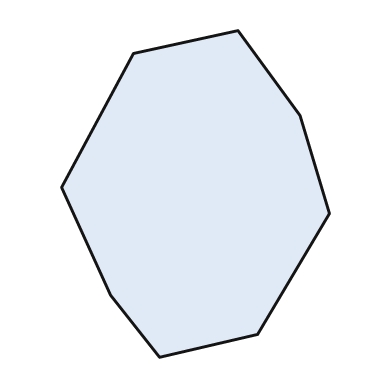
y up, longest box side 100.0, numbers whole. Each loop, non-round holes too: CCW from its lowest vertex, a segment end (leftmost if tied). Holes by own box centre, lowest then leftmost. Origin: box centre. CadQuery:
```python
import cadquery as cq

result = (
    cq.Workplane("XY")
    .moveTo(-11.0, -50.0)
    .lineTo(19.0, -43.0)
    .lineTo(41.0, -6.0)
    .lineTo(32.0, 24.0)
    .lineTo(13.0, 50.0)
    .lineTo(-19.0, 43.0)
    .lineTo(-41.0, 2.0)
    .lineTo(-26.0, -31.0)
    .close()
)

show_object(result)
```